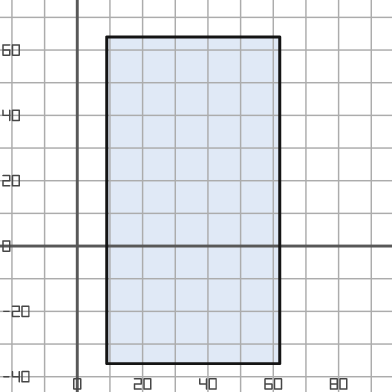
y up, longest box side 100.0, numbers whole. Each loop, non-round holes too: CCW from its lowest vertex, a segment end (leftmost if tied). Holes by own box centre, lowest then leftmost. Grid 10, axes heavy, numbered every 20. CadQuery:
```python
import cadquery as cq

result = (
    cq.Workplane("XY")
    .moveTo(9.0, -36.0)
    .lineTo(62.0, -36.0)
    .lineTo(62.0, 64.0)
    .lineTo(9.0, 64.0)
    .close()
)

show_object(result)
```